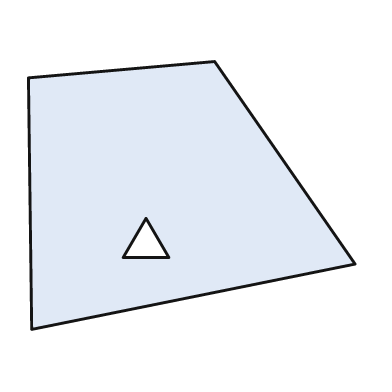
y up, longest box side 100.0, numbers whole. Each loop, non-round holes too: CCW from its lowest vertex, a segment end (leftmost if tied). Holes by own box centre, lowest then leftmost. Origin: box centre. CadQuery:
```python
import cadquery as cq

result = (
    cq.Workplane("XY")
    .moveTo(-49.0, -41.0)
    .lineTo(50.0, -21.0)
    .lineTo(7.0, 41.0)
    .lineTo(-50.0, 36.0)
    .close()
    .moveTo(-21.0, -19.0)
    .lineTo(-7.0, -19.0)
    .lineTo(-14.0, -7.0)
    .close()
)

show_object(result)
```